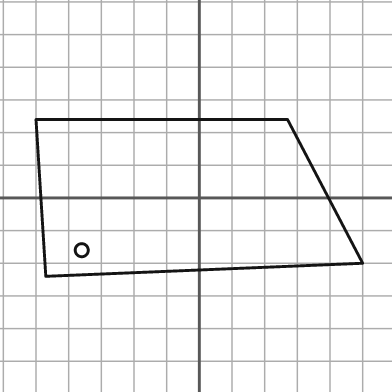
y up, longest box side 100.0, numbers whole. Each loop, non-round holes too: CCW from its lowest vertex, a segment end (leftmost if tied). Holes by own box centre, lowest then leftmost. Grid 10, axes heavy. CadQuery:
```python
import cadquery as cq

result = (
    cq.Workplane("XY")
    .moveTo(-47.0, -24.0)
    .lineTo(50.0, -20.0)
    .lineTo(27.0, 24.0)
    .lineTo(-50.0, 24.0)
    .close()
    .moveTo(-36.0, -16.0)
    .circle(2.0)
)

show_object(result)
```